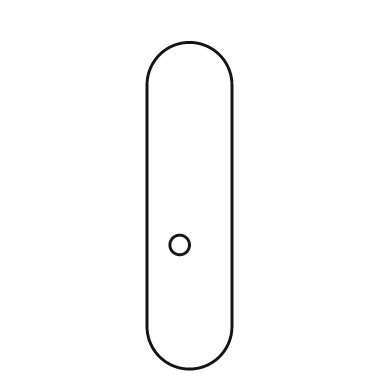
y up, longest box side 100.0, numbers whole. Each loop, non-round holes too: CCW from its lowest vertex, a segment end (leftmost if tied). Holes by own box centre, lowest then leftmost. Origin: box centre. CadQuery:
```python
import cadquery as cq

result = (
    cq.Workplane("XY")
    .moveTo(-13.0, -37.0)
    .threePointArc((0.0, -50.0), (13.0, -37.0))
    .lineTo(13.0, 37.0)
    .threePointArc((0.0, 50.0), (-13.0, 37.0))
    .close()
    .moveTo(-3.0, -12.0)
    .circle(3.0)
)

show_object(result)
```